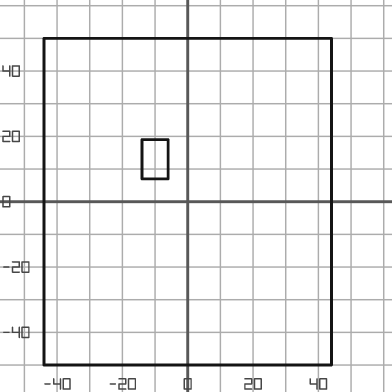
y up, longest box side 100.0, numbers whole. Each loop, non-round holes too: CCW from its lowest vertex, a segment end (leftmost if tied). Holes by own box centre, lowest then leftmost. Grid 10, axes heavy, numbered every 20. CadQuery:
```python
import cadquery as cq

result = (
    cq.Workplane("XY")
    .moveTo(-44.0, -50.0)
    .lineTo(44.0, -50.0)
    .lineTo(44.0, 50.0)
    .lineTo(-44.0, 50.0)
    .close()
    .moveTo(-14.0, 7.0)
    .lineTo(-6.0, 7.0)
    .lineTo(-6.0, 19.0)
    .lineTo(-14.0, 19.0)
    .close()
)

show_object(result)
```